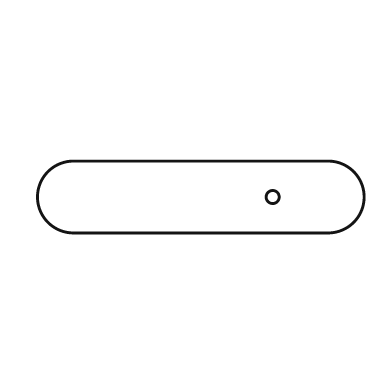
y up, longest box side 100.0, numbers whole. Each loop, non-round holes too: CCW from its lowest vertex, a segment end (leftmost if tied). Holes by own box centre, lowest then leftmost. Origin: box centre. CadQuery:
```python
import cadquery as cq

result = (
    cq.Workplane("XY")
    .moveTo(-39.0, -11.0)
    .lineTo(39.0, -11.0)
    .threePointArc((50.0, 0.0), (39.0, 11.0))
    .lineTo(-39.0, 11.0)
    .threePointArc((-50.0, 0.0), (-39.0, -11.0))
    .close()
    .moveTo(22.0, 0.0)
    .circle(2.0)
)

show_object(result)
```